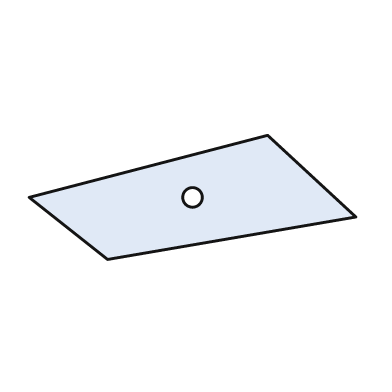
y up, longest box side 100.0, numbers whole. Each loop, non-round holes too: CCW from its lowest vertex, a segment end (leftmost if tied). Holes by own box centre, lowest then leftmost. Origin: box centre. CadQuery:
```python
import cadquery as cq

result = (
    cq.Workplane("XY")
    .moveTo(-26.0, -19.0)
    .lineTo(50.0, -6.0)
    .lineTo(23.0, 19.0)
    .lineTo(-50.0, 0.0)
    .close()
    .moveTo(0.0, 0.0)
    .circle(3.0)
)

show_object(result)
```